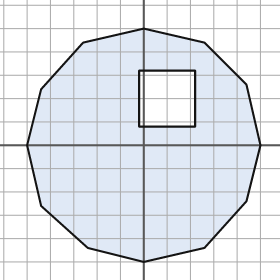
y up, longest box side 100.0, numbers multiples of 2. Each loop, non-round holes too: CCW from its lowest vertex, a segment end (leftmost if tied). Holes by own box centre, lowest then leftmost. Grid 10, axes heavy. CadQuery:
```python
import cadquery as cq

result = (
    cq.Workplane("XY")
    .moveTo(0.0, -50.0)
    .lineTo(26.0, -44.0)
    .lineTo(44.0, -24.0)
    .lineTo(50.0, 0.0)
    .lineTo(44.0, 26.0)
    .lineTo(26.0, 44.0)
    .lineTo(0.0, 50.0)
    .lineTo(-26.0, 44.0)
    .lineTo(-44.0, 24.0)
    .lineTo(-50.0, 0.0)
    .lineTo(-44.0, -26.0)
    .lineTo(-24.0, -44.0)
    .close()
    .moveTo(-2.0, 8.0)
    .lineTo(22.0, 8.0)
    .lineTo(22.0, 32.0)
    .lineTo(-2.0, 32.0)
    .close()
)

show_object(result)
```